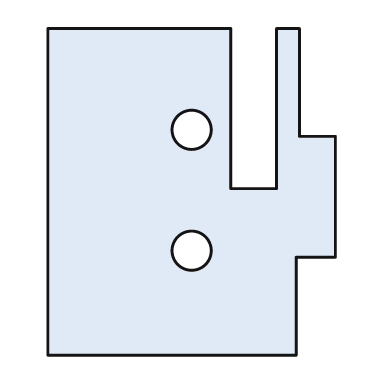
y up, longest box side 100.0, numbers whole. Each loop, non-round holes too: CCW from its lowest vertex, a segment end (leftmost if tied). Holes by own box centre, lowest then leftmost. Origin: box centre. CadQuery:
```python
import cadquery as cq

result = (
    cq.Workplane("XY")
    .moveTo(-44.0, -50.0)
    .lineTo(32.0, -50.0)
    .lineTo(32.0, -20.0)
    .lineTo(44.0, -20.0)
    .lineTo(44.0, 17.0)
    .lineTo(33.0, 17.0)
    .lineTo(33.0, 50.0)
    .lineTo(26.0, 50.0)
    .lineTo(26.0, 1.0)
    .lineTo(12.0, 1.0)
    .lineTo(12.0, 50.0)
    .lineTo(-44.0, 50.0)
    .close()
    .moveTo(0.0, -18.0)
    .circle(6.0)
    .moveTo(0.0, 19.0)
    .circle(6.0)
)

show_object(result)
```